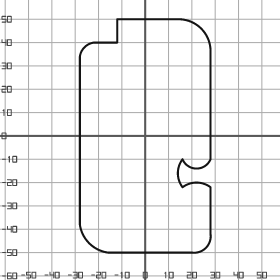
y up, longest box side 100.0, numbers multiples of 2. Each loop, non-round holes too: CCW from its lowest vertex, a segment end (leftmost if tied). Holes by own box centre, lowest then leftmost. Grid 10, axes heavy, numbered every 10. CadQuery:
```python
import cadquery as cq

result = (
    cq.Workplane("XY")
    .moveTo(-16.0, -50.0)
    .lineTo(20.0, -50.0)
    .threePointArc((26.0, -48.0), (28.0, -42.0))
    .lineTo(28.0, -22.0)
    .threePointArc((22.0, -20.0), (16.0, -22.0))
    .threePointArc((14.0, -16.0), (16.0, -10.0))
    .threePointArc((22.0, -14.0), (28.0, -10.0))
    .lineTo(28.0, 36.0)
    .threePointArc((24.0, 46.0), (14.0, 50.0))
    .lineTo(-12.0, 50.0)
    .lineTo(-12.0, 40.0)
    .lineTo(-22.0, 40.0)
    .threePointArc((-26.0, 38.0), (-28.0, 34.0))
    .lineTo(-28.0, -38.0)
    .threePointArc((-24.0, -46.0), (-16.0, -50.0))
    .close()
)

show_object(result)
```